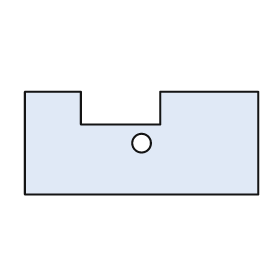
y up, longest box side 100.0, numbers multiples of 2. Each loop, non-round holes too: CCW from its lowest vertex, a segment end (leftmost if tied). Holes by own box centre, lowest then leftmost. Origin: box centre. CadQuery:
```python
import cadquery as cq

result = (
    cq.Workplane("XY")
    .moveTo(-50.0, -22.0)
    .lineTo(50.0, -22.0)
    .lineTo(50.0, 22.0)
    .lineTo(8.0, 22.0)
    .lineTo(8.0, 8.0)
    .lineTo(-26.0, 8.0)
    .lineTo(-26.0, 22.0)
    .lineTo(-50.0, 22.0)
    .close()
    .moveTo(0.0, 0.0)
    .circle(4.0)
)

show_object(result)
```